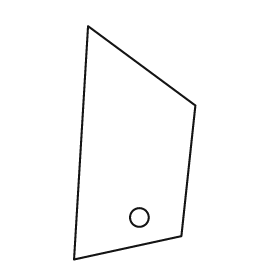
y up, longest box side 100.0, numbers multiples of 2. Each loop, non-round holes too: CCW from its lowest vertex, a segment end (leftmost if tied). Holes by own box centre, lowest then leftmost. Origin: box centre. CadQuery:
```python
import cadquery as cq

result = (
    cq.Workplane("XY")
    .moveTo(-26.0, -50.0)
    .lineTo(20.0, -40.0)
    .lineTo(26.0, 16.0)
    .lineTo(-20.0, 50.0)
    .close()
    .moveTo(2.0, -32.0)
    .circle(4.0)
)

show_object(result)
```